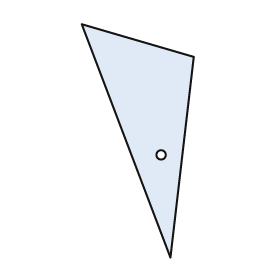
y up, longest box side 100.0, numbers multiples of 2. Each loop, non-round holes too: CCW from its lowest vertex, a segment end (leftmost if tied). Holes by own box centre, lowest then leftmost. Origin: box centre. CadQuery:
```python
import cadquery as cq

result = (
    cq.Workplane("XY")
    .moveTo(14.0, -50.0)
    .lineTo(24.0, 36.0)
    .lineTo(-24.0, 50.0)
    .close()
    .moveTo(10.0, -6.0)
    .circle(2.0)
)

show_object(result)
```